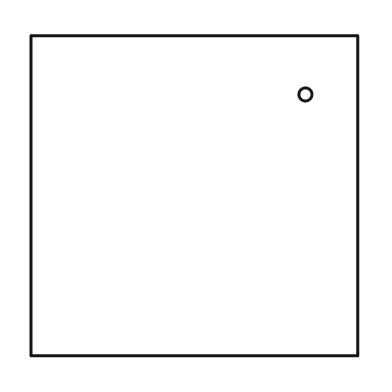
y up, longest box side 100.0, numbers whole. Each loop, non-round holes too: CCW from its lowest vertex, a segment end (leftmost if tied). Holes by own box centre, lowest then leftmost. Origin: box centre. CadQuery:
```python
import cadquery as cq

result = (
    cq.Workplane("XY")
    .moveTo(-50.0, -49.0)
    .lineTo(50.0, -49.0)
    .lineTo(50.0, 49.0)
    .lineTo(-50.0, 49.0)
    .close()
    .moveTo(34.0, 31.0)
    .circle(2.0)
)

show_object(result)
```